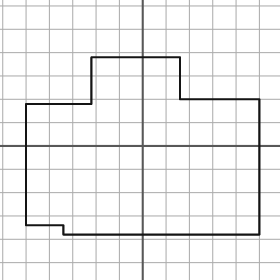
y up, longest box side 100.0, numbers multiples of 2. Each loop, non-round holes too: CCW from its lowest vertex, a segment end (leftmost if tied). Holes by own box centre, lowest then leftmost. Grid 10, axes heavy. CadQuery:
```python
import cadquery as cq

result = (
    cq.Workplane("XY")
    .moveTo(-34.0, -38.0)
    .lineTo(50.0, -38.0)
    .lineTo(50.0, 20.0)
    .lineTo(16.0, 20.0)
    .lineTo(16.0, 38.0)
    .lineTo(-22.0, 38.0)
    .lineTo(-22.0, 18.0)
    .lineTo(-50.0, 18.0)
    .lineTo(-50.0, -34.0)
    .lineTo(-34.0, -34.0)
    .close()
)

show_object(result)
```